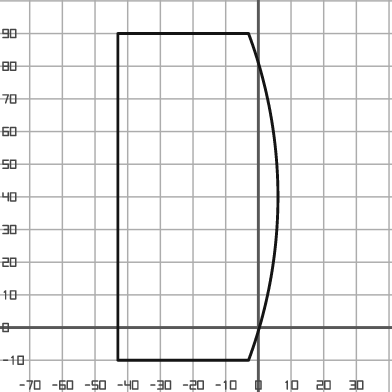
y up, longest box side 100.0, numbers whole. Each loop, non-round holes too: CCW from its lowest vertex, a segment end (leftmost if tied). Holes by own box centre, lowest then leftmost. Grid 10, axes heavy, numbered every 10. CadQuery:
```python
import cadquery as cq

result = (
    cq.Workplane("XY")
    .moveTo(-43.0, -10.0)
    .lineTo(-3.0, -10.0)
    .threePointArc((6.0, 40.0), (-3.0, 90.0))
    .lineTo(-43.0, 90.0)
    .close()
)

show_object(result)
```